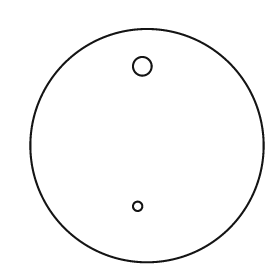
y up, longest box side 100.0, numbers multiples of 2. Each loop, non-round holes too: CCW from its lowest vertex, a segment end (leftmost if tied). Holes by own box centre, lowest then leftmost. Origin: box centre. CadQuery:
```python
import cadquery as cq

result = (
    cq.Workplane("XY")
    .moveTo(0.0, 0.0)
    .circle(50.0)
    .moveTo(-4.0, -26.0)
    .circle(2.0)
    .moveTo(-2.0, 34.0)
    .circle(4.0)
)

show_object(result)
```